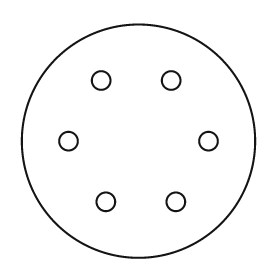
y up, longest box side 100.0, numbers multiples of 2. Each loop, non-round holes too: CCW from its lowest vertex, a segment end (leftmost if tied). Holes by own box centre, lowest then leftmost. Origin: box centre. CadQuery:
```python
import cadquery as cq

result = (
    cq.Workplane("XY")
    .moveTo(0.0, 0.0)
    .circle(50.0)
    .moveTo(-14.0, -26.0)
    .circle(4.0)
    .moveTo(16.0, -26.0)
    .circle(4.0)
    .moveTo(-30.0, 0.0)
    .circle(4.0)
    .moveTo(30.0, 0.0)
    .circle(4.0)
    .moveTo(-16.0, 26.0)
    .circle(4.0)
    .moveTo(14.0, 26.0)
    .circle(4.0)
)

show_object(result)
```